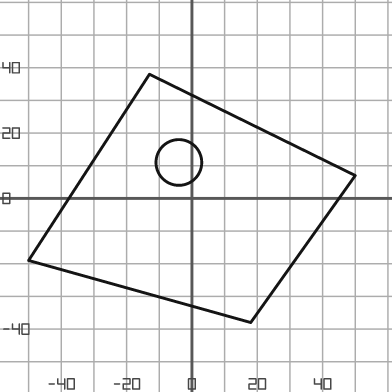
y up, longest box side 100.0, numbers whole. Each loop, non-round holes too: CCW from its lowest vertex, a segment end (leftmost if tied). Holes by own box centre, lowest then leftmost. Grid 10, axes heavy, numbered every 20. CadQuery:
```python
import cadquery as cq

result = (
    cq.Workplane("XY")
    .moveTo(18.0, -38.0)
    .lineTo(50.0, 7.0)
    .lineTo(-13.0, 38.0)
    .lineTo(-50.0, -19.0)
    .close()
    .moveTo(-4.0, 11.0)
    .circle(7.0)
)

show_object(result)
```